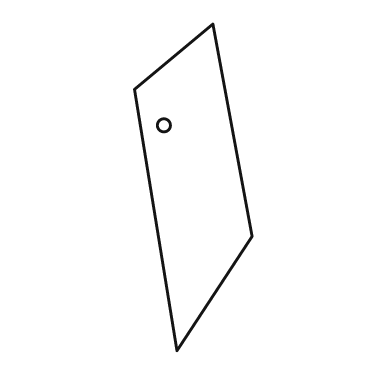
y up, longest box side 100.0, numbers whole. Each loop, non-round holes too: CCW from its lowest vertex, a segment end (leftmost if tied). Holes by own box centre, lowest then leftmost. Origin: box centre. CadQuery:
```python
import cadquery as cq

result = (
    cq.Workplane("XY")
    .moveTo(-5.0, -50.0)
    .lineTo(18.0, -15.0)
    .lineTo(6.0, 50.0)
    .lineTo(-18.0, 30.0)
    .close()
    .moveTo(-9.0, 19.0)
    .circle(2.0)
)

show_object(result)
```